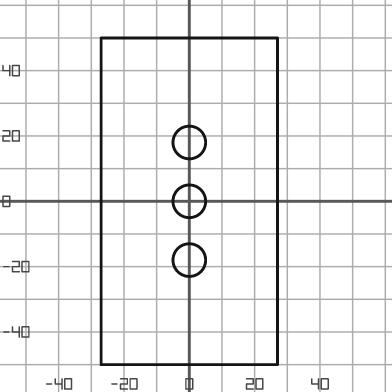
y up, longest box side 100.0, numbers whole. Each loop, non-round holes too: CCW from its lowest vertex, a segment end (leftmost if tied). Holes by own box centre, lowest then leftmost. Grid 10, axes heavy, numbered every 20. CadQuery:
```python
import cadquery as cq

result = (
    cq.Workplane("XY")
    .moveTo(-27.0, -50.0)
    .lineTo(27.0, -50.0)
    .lineTo(27.0, 50.0)
    .lineTo(-27.0, 50.0)
    .close()
    .moveTo(0.0, -18.0)
    .circle(5.0)
    .moveTo(0.0, 0.0)
    .circle(5.0)
    .moveTo(0.0, 18.0)
    .circle(5.0)
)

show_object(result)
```